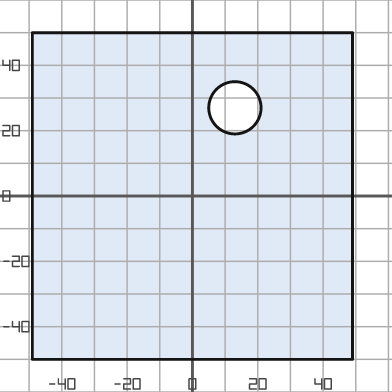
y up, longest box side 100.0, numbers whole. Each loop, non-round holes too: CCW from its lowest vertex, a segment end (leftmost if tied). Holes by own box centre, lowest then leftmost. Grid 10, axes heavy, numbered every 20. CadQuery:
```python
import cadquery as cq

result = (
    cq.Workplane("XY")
    .moveTo(-49.0, -50.0)
    .lineTo(49.0, -50.0)
    .lineTo(49.0, 50.0)
    .lineTo(-49.0, 50.0)
    .close()
    .moveTo(13.0, 27.0)
    .circle(8.0)
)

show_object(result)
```